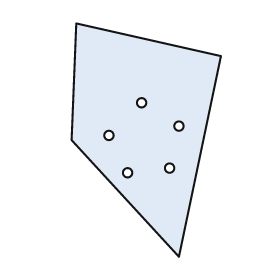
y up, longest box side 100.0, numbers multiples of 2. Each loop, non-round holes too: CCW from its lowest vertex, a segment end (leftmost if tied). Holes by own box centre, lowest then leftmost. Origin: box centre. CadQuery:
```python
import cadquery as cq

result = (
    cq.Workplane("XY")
    .moveTo(14.0, -50.0)
    .lineTo(32.0, 36.0)
    .lineTo(-30.0, 50.0)
    .lineTo(-32.0, 0.0)
    .close()
    .moveTo(-8.0, -14.0)
    .circle(2.0)
    .moveTo(10.0, -12.0)
    .circle(2.0)
    .moveTo(-16.0, 2.0)
    .circle(2.0)
    .moveTo(14.0, 6.0)
    .circle(2.0)
    .moveTo(-2.0, 16.0)
    .circle(2.0)
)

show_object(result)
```